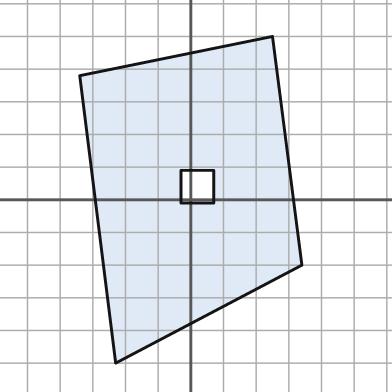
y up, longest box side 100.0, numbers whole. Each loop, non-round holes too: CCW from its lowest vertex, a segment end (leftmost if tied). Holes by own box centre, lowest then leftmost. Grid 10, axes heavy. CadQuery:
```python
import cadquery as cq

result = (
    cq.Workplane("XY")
    .moveTo(-23.0, -50.0)
    .lineTo(34.0, -20.0)
    .lineTo(25.0, 50.0)
    .lineTo(-34.0, 38.0)
    .close()
    .moveTo(-3.0, -1.0)
    .lineTo(7.0, -1.0)
    .lineTo(7.0, 9.0)
    .lineTo(-3.0, 9.0)
    .close()
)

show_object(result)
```